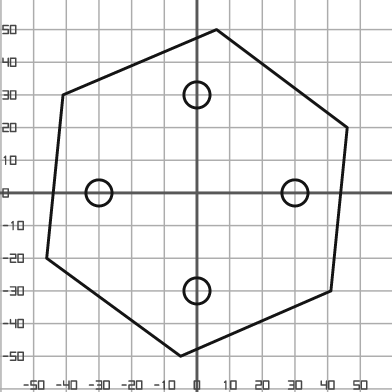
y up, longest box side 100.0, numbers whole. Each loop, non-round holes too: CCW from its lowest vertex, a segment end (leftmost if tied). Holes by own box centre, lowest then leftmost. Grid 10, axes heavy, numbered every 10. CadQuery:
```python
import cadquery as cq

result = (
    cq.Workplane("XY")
    .moveTo(-5.0, -50.0)
    .lineTo(41.0, -30.0)
    .lineTo(46.0, 20.0)
    .lineTo(6.0, 50.0)
    .lineTo(-41.0, 30.0)
    .lineTo(-46.0, -20.0)
    .close()
    .moveTo(0.0, -30.0)
    .circle(4.0)
    .moveTo(-30.0, 0.0)
    .circle(4.0)
    .moveTo(30.0, 0.0)
    .circle(4.0)
    .moveTo(0.0, 30.0)
    .circle(4.0)
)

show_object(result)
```